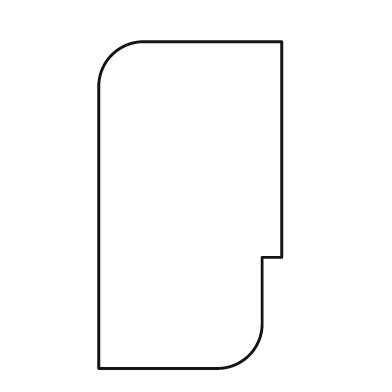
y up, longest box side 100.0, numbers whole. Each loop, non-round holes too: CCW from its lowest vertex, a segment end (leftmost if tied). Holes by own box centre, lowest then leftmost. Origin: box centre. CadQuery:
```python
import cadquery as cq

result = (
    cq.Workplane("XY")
    .moveTo(-28.0, -50.0)
    .lineTo(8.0, -50.0)
    .threePointArc((18.0, -46.0), (22.0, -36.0))
    .lineTo(22.0, -16.0)
    .lineTo(28.0, -16.0)
    .lineTo(28.0, 50.0)
    .lineTo(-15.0, 50.0)
    .threePointArc((-24.0, 46.0), (-28.0, 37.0))
    .close()
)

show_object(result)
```